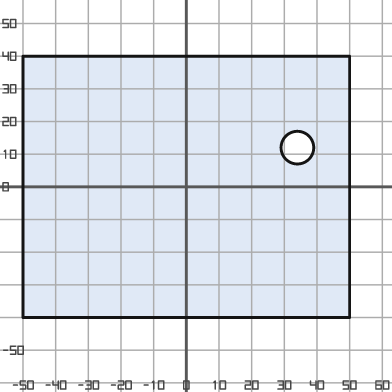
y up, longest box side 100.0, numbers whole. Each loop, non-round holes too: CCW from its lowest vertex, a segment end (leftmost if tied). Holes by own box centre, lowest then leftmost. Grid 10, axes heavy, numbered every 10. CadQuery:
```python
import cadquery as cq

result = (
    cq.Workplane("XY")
    .moveTo(-50.0, -40.0)
    .lineTo(50.0, -40.0)
    .lineTo(50.0, 40.0)
    .lineTo(-50.0, 40.0)
    .close()
    .moveTo(34.0, 12.0)
    .circle(5.0)
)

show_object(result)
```